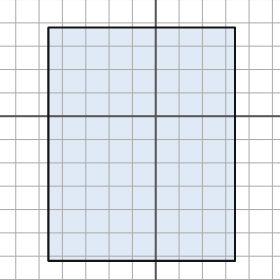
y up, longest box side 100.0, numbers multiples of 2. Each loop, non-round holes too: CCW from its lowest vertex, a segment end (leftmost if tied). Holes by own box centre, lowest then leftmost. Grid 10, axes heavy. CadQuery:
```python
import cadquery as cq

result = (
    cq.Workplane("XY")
    .moveTo(-46.0, -62.0)
    .lineTo(34.0, -62.0)
    .lineTo(34.0, 38.0)
    .lineTo(-46.0, 38.0)
    .close()
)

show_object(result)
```